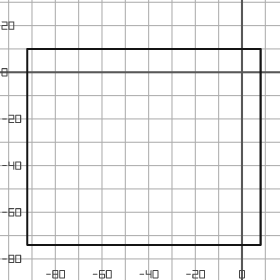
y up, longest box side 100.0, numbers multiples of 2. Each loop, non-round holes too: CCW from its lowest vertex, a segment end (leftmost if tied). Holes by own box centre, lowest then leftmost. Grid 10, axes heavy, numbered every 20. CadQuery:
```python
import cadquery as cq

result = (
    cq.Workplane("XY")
    .moveTo(-92.0, -74.0)
    .lineTo(8.0, -74.0)
    .lineTo(8.0, 10.0)
    .lineTo(-92.0, 10.0)
    .close()
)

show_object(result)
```